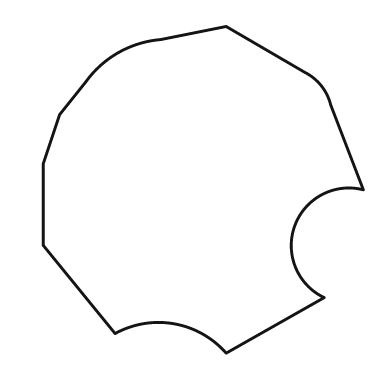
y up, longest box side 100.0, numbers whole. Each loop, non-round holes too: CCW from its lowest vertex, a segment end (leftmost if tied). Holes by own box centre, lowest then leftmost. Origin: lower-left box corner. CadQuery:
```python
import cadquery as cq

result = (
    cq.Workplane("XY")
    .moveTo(56.0, 0.0)
    .lineTo(86.0, 17.0)
    .threePointArc((77.0, 39.0), (98.0, 50.0))
    .lineTo(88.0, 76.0)
    .threePointArc((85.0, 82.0), (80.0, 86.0))
    .lineTo(56.0, 100.0)
    .lineTo(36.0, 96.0)
    .threePointArc((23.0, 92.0), (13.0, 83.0))
    .lineTo(5.0, 73.0)
    .lineTo(0.0, 58.0)
    .lineTo(0.0, 33.0)
    .lineTo(22.0, 6.0)
    .threePointArc((40.0, 9.0), (56.0, 0.0))
    .close()
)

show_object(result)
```